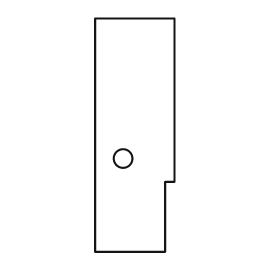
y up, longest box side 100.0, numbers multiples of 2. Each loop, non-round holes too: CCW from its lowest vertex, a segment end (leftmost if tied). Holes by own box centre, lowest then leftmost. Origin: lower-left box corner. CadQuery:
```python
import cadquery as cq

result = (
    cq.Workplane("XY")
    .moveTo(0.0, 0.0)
    .lineTo(30.0, 0.0)
    .lineTo(30.0, 30.0)
    .lineTo(34.0, 30.0)
    .lineTo(34.0, 100.0)
    .lineTo(0.0, 100.0)
    .close()
    .moveTo(12.0, 40.0)
    .circle(4.0)
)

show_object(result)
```